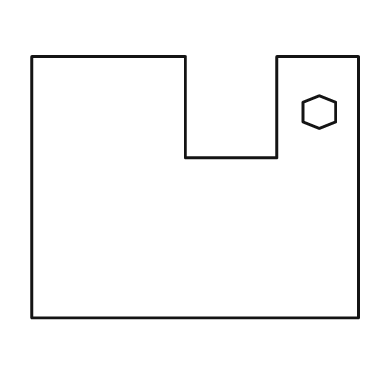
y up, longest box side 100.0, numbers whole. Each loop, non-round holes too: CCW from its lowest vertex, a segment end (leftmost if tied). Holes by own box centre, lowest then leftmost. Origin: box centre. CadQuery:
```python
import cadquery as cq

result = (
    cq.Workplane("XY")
    .moveTo(-50.0, -40.0)
    .lineTo(50.0, -40.0)
    .lineTo(50.0, 40.0)
    .lineTo(25.0, 40.0)
    .lineTo(25.0, 9.0)
    .lineTo(-3.0, 9.0)
    .lineTo(-3.0, 40.0)
    .lineTo(-50.0, 40.0)
    .close()
    .moveTo(38.0, 18.0)
    .lineTo(43.0, 20.0)
    .lineTo(43.0, 26.0)
    .lineTo(38.0, 28.0)
    .lineTo(33.0, 26.0)
    .lineTo(33.0, 20.0)
    .close()
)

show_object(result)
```